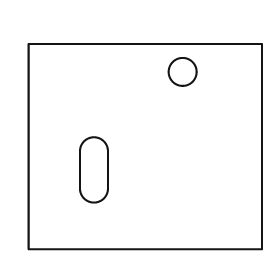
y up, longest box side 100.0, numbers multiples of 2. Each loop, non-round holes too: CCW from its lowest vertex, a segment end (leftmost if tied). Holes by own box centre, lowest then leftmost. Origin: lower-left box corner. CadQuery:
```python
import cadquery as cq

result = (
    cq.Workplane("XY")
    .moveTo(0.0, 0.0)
    .lineTo(100.0, 0.0)
    .lineTo(100.0, 88.0)
    .lineTo(0.0, 88.0)
    .close()
    .moveTo(22.0, 26.0)
    .threePointArc((28.0, 20.0), (34.0, 26.0))
    .lineTo(34.0, 42.0)
    .threePointArc((28.0, 48.0), (22.0, 42.0))
    .close()
    .moveTo(66.0, 76.0)
    .circle(6.0)
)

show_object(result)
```